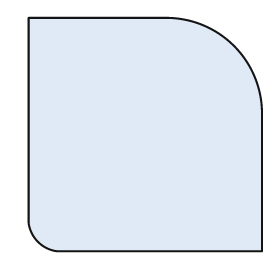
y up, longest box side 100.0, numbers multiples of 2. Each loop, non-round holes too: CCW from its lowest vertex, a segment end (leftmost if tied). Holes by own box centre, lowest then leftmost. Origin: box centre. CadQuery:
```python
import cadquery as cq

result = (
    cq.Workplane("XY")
    .moveTo(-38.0, -50.0)
    .lineTo(50.0, -50.0)
    .lineTo(50.0, 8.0)
    .threePointArc((38.0, 38.0), (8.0, 50.0))
    .lineTo(-50.0, 50.0)
    .lineTo(-50.0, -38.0)
    .threePointArc((-46.0, -46.0), (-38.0, -50.0))
    .close()
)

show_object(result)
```